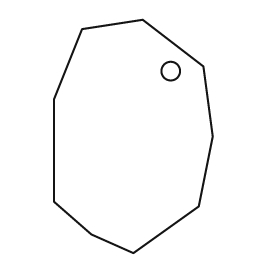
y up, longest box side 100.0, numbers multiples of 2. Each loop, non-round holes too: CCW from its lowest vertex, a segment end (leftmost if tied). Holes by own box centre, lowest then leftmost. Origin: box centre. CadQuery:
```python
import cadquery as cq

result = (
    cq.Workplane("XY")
    .moveTo(0.0, -50.0)
    .lineTo(28.0, -30.0)
    .lineTo(34.0, 0.0)
    .lineTo(30.0, 30.0)
    .lineTo(4.0, 50.0)
    .lineTo(-22.0, 46.0)
    .lineTo(-34.0, 16.0)
    .lineTo(-34.0, -28.0)
    .lineTo(-18.0, -42.0)
    .close()
    .moveTo(16.0, 28.0)
    .circle(4.0)
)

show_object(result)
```